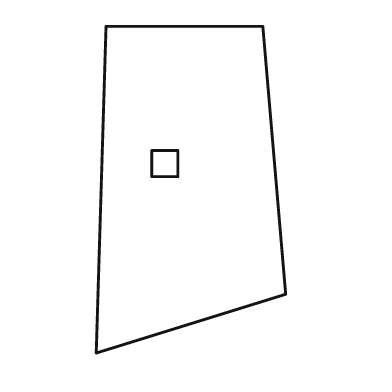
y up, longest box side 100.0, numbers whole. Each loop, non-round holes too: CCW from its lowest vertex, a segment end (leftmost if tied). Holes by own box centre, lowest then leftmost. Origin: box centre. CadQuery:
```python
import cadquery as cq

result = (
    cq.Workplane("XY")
    .moveTo(-29.0, -50.0)
    .lineTo(29.0, -32.0)
    .lineTo(22.0, 50.0)
    .lineTo(-26.0, 50.0)
    .close()
    .moveTo(-12.0, 4.0)
    .lineTo(-4.0, 4.0)
    .lineTo(-4.0, 12.0)
    .lineTo(-12.0, 12.0)
    .close()
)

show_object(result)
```